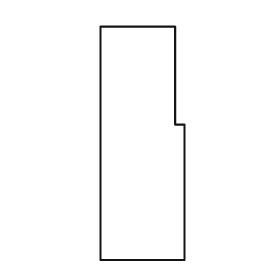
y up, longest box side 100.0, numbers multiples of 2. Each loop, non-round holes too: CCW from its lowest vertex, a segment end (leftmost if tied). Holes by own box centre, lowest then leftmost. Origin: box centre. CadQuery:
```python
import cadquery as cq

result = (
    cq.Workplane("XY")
    .moveTo(-18.0, -50.0)
    .lineTo(18.0, -50.0)
    .lineTo(18.0, 8.0)
    .lineTo(14.0, 8.0)
    .lineTo(14.0, 50.0)
    .lineTo(-18.0, 50.0)
    .close()
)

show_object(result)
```